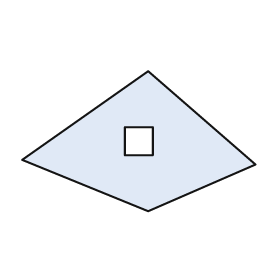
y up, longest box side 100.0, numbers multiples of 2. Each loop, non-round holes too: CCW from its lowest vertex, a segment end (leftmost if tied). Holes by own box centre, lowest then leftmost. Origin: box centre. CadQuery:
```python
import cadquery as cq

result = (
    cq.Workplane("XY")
    .moveTo(4.0, -30.0)
    .lineTo(50.0, -10.0)
    .lineTo(4.0, 30.0)
    .lineTo(-50.0, -8.0)
    .close()
    .moveTo(-6.0, -6.0)
    .lineTo(6.0, -6.0)
    .lineTo(6.0, 6.0)
    .lineTo(-6.0, 6.0)
    .close()
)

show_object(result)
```